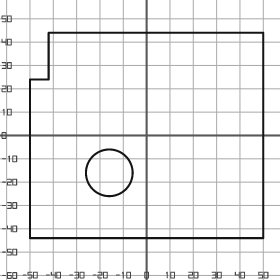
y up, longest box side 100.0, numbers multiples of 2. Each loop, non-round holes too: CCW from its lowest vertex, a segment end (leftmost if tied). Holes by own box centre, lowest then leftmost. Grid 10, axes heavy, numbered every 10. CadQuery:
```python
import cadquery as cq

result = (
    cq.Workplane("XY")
    .moveTo(-50.0, -44.0)
    .lineTo(50.0, -44.0)
    .lineTo(50.0, 44.0)
    .lineTo(-42.0, 44.0)
    .lineTo(-42.0, 24.0)
    .lineTo(-50.0, 24.0)
    .close()
    .moveTo(-16.0, -16.0)
    .circle(10.0)
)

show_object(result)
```